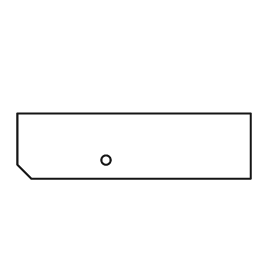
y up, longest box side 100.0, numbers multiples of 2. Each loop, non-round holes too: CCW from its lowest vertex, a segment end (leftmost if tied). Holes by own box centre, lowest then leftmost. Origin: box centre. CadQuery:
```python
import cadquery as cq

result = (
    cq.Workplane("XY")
    .moveTo(-44.0, -14.0)
    .lineTo(50.0, -14.0)
    .lineTo(50.0, 14.0)
    .lineTo(-50.0, 14.0)
    .lineTo(-50.0, -8.0)
    .close()
    .moveTo(-12.0, -6.0)
    .circle(2.0)
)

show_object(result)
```